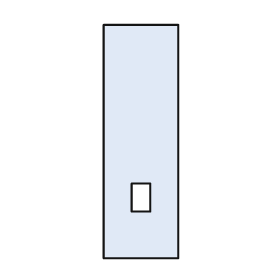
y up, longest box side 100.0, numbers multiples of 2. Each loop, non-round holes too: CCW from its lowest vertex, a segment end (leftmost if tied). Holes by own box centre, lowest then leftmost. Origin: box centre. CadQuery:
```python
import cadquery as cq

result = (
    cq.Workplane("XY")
    .moveTo(-16.0, -50.0)
    .lineTo(16.0, -50.0)
    .lineTo(16.0, 50.0)
    .lineTo(-16.0, 50.0)
    .close()
    .moveTo(-4.0, -30.0)
    .lineTo(4.0, -30.0)
    .lineTo(4.0, -18.0)
    .lineTo(-4.0, -18.0)
    .close()
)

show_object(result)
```